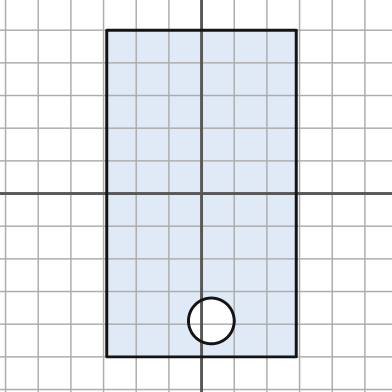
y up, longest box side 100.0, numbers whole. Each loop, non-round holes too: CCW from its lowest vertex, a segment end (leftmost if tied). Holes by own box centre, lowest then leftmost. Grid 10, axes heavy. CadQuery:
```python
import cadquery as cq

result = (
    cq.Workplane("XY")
    .moveTo(-29.0, -50.0)
    .lineTo(29.0, -50.0)
    .lineTo(29.0, 50.0)
    .lineTo(-29.0, 50.0)
    .close()
    .moveTo(3.0, -39.0)
    .circle(7.0)
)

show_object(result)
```